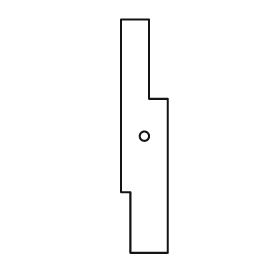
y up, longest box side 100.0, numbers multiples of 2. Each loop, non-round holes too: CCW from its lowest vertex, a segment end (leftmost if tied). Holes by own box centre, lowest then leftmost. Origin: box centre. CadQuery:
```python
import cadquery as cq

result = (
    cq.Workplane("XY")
    .moveTo(-6.0, -50.0)
    .lineTo(10.0, -50.0)
    .lineTo(10.0, 16.0)
    .lineTo(2.0, 16.0)
    .lineTo(2.0, 50.0)
    .lineTo(-10.0, 50.0)
    .lineTo(-10.0, -24.0)
    .lineTo(-6.0, -24.0)
    .close()
    .moveTo(0.0, 0.0)
    .circle(2.0)
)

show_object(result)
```